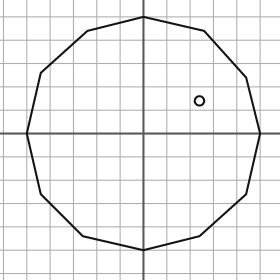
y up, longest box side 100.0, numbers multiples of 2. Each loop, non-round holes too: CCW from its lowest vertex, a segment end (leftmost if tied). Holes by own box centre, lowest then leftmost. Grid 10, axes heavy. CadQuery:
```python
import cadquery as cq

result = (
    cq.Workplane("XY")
    .moveTo(0.0, -50.0)
    .lineTo(24.0, -44.0)
    .lineTo(44.0, -26.0)
    .lineTo(50.0, 0.0)
    .lineTo(44.0, 24.0)
    .lineTo(26.0, 44.0)
    .lineTo(0.0, 50.0)
    .lineTo(-24.0, 44.0)
    .lineTo(-44.0, 26.0)
    .lineTo(-50.0, 0.0)
    .lineTo(-44.0, -26.0)
    .lineTo(-26.0, -44.0)
    .close()
    .moveTo(24.0, 14.0)
    .circle(2.0)
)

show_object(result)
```